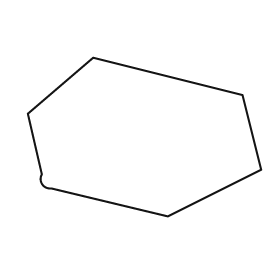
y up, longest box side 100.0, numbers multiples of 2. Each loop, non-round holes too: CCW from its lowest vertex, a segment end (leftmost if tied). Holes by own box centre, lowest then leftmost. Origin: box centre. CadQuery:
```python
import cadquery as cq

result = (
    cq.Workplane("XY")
    .moveTo(10.0, -34.0)
    .lineTo(50.0, -14.0)
    .lineTo(42.0, 18.0)
    .lineTo(-22.0, 34.0)
    .lineTo(-50.0, 10.0)
    .lineTo(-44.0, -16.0)
    .threePointArc((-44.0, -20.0), (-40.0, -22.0))
    .close()
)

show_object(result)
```